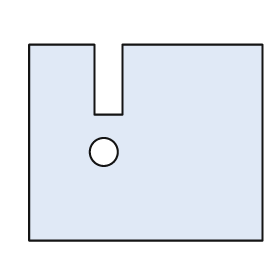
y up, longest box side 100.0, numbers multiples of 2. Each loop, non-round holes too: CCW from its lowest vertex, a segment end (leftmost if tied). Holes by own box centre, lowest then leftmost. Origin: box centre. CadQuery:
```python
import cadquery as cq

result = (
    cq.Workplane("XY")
    .moveTo(-50.0, -42.0)
    .lineTo(50.0, -42.0)
    .lineTo(50.0, 42.0)
    .lineTo(-10.0, 42.0)
    .lineTo(-10.0, 12.0)
    .lineTo(-22.0, 12.0)
    .lineTo(-22.0, 42.0)
    .lineTo(-50.0, 42.0)
    .close()
    .moveTo(-18.0, -4.0)
    .circle(6.0)
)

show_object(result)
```